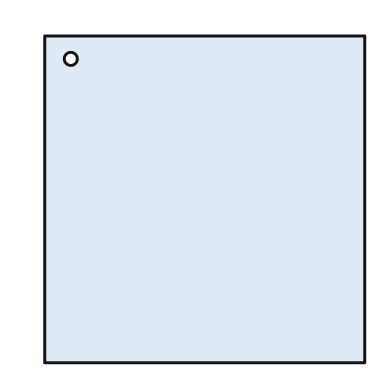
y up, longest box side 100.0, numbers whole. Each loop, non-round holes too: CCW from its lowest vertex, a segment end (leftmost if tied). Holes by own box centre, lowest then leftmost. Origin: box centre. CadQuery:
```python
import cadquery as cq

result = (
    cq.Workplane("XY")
    .moveTo(-49.0, -50.0)
    .lineTo(49.0, -50.0)
    .lineTo(49.0, 50.0)
    .lineTo(-49.0, 50.0)
    .close()
    .moveTo(-41.0, 43.0)
    .circle(2.0)
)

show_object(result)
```